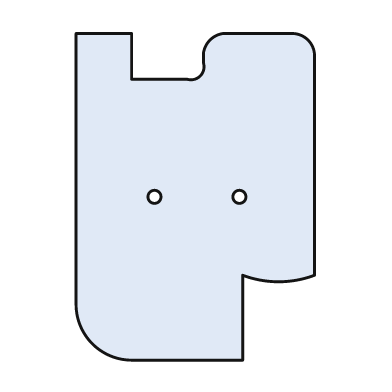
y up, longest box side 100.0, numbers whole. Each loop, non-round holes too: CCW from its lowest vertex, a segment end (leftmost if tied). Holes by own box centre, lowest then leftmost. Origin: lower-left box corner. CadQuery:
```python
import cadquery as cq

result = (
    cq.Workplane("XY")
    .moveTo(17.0, 0.0)
    .lineTo(51.0, 0.0)
    .lineTo(51.0, 26.0)
    .threePointArc((62.0, 24.0), (73.0, 26.0))
    .lineTo(73.0, 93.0)
    .threePointArc((71.0, 98.0), (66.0, 100.0))
    .lineTo(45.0, 100.0)
    .threePointArc((41.0, 98.0), (39.0, 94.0))
    .lineTo(39.0, 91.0)
    .threePointArc((38.0, 87.0), (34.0, 86.0))
    .lineTo(17.0, 86.0)
    .lineTo(17.0, 100.0)
    .lineTo(0.0, 100.0)
    .lineTo(0.0, 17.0)
    .threePointArc((5.0, 5.0), (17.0, 0.0))
    .close()
    .moveTo(24.0, 50.0)
    .circle(2.0)
    .moveTo(50.0, 50.0)
    .circle(2.0)
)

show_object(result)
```